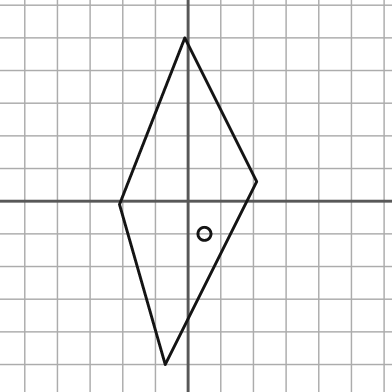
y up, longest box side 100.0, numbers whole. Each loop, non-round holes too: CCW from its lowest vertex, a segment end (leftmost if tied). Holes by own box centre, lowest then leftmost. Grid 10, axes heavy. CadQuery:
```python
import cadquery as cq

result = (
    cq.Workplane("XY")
    .moveTo(-7.0, -50.0)
    .lineTo(21.0, 6.0)
    .lineTo(-1.0, 50.0)
    .lineTo(-21.0, -1.0)
    .close()
    .moveTo(5.0, -10.0)
    .circle(2.0)
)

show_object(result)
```